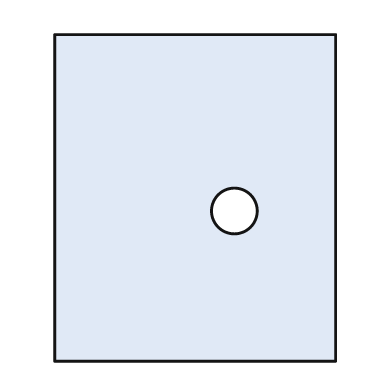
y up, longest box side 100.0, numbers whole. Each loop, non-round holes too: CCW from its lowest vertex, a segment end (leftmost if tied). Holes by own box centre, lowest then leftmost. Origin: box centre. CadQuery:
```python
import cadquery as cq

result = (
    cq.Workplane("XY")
    .moveTo(-43.0, -50.0)
    .lineTo(43.0, -50.0)
    .lineTo(43.0, 50.0)
    .lineTo(-43.0, 50.0)
    .close()
    .moveTo(12.0, -4.0)
    .circle(7.0)
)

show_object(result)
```